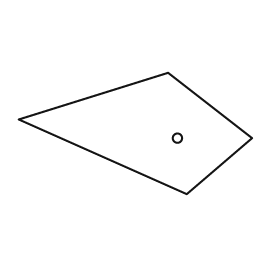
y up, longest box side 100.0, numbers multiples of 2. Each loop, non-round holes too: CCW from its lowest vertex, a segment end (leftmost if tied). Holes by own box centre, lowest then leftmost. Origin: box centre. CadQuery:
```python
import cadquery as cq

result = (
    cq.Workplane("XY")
    .moveTo(22.0, -26.0)
    .lineTo(50.0, -2.0)
    .lineTo(14.0, 26.0)
    .lineTo(-50.0, 6.0)
    .close()
    .moveTo(18.0, -2.0)
    .circle(2.0)
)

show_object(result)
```